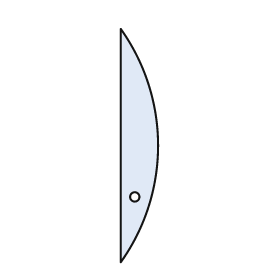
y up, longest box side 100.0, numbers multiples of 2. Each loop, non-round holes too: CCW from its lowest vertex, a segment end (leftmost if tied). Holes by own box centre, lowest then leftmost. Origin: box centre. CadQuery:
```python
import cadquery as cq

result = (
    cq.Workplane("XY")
    .moveTo(-8.0, -50.0)
    .threePointArc((8.0, 0.0), (-8.0, 50.0))
    .close()
    .moveTo(-2.0, -22.0)
    .circle(2.0)
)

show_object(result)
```